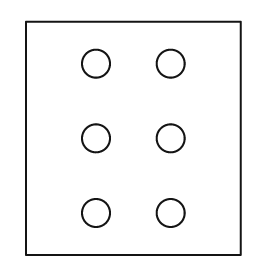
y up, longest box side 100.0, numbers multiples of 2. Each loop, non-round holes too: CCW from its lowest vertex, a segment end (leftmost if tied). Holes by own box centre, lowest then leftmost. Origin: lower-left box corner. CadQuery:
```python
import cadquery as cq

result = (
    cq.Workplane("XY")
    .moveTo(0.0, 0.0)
    .lineTo(92.0, 0.0)
    .lineTo(92.0, 100.0)
    .lineTo(0.0, 100.0)
    .close()
    .moveTo(30.0, 18.0)
    .circle(6.0)
    .moveTo(62.0, 18.0)
    .circle(6.0)
    .moveTo(30.0, 50.0)
    .circle(6.0)
    .moveTo(62.0, 50.0)
    .circle(6.0)
    .moveTo(30.0, 82.0)
    .circle(6.0)
    .moveTo(62.0, 82.0)
    .circle(6.0)
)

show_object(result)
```